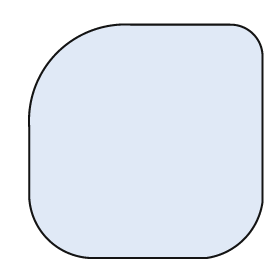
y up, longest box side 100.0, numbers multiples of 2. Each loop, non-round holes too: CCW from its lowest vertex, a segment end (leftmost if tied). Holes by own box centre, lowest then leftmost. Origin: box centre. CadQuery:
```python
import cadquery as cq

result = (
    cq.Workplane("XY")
    .moveTo(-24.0, -50.0)
    .lineTo(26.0, -50.0)
    .threePointArc((42.0, -42.0), (50.0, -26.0))
    .lineTo(50.0, 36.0)
    .threePointArc((46.0, 46.0), (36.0, 50.0))
    .lineTo(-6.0, 50.0)
    .threePointArc((-38.0, 38.0), (-50.0, 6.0))
    .lineTo(-50.0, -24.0)
    .threePointArc((-42.0, -42.0), (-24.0, -50.0))
    .close()
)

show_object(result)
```